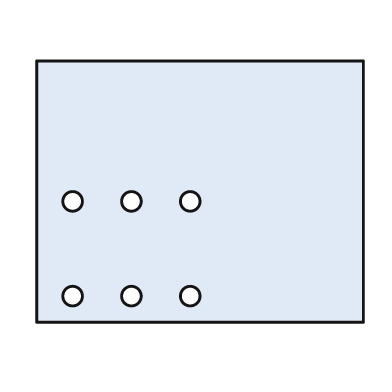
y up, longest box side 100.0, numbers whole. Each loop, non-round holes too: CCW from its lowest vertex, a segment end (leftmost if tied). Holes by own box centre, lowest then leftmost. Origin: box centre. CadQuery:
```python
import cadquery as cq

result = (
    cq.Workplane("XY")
    .moveTo(-50.0, -40.0)
    .lineTo(50.0, -40.0)
    .lineTo(50.0, 40.0)
    .lineTo(-50.0, 40.0)
    .close()
    .moveTo(-39.0, -32.0)
    .circle(3.0)
    .moveTo(-21.0, -32.0)
    .circle(3.0)
    .moveTo(-3.0, -32.0)
    .circle(3.0)
    .moveTo(-39.0, -3.0)
    .circle(3.0)
    .moveTo(-21.0, -3.0)
    .circle(3.0)
    .moveTo(-3.0, -3.0)
    .circle(3.0)
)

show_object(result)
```